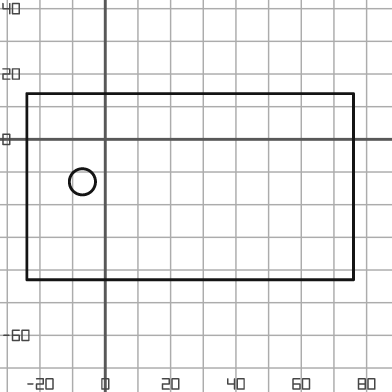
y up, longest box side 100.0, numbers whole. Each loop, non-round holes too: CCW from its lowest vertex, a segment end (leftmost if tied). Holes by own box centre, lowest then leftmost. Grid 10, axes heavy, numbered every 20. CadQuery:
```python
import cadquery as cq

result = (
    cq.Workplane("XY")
    .moveTo(-24.0, -43.0)
    .lineTo(76.0, -43.0)
    .lineTo(76.0, 14.0)
    .lineTo(-24.0, 14.0)
    .close()
    .moveTo(-7.0, -13.0)
    .circle(4.0)
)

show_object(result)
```